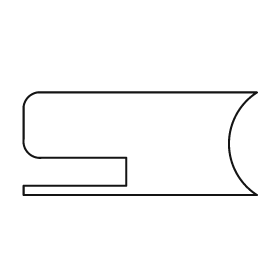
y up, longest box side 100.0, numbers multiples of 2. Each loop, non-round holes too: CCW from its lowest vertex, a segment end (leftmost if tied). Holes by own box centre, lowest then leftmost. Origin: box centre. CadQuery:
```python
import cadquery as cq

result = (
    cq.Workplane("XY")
    .moveTo(-50.0, -22.0)
    .lineTo(50.0, -22.0)
    .threePointArc((38.0, 0.0), (50.0, 22.0))
    .lineTo(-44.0, 22.0)
    .threePointArc((-48.0, 20.0), (-50.0, 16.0))
    .lineTo(-50.0, 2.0)
    .threePointArc((-48.0, -4.0), (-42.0, -6.0))
    .lineTo(-6.0, -6.0)
    .lineTo(-6.0, -18.0)
    .lineTo(-50.0, -18.0)
    .close()
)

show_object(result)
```